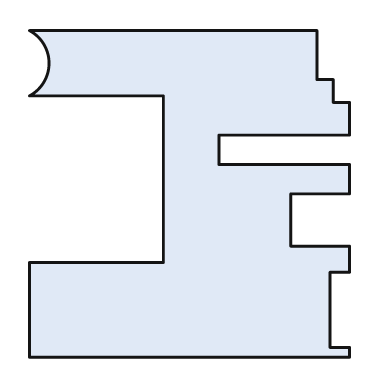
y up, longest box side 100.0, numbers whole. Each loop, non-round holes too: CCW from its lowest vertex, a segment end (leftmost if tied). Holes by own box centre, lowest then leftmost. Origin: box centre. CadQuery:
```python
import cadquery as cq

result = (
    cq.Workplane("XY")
    .moveTo(-49.0, -50.0)
    .lineTo(49.0, -50.0)
    .lineTo(49.0, -47.0)
    .lineTo(43.0, -47.0)
    .lineTo(43.0, -24.0)
    .lineTo(49.0, -24.0)
    .lineTo(49.0, -16.0)
    .lineTo(31.0, -16.0)
    .lineTo(31.0, 0.0)
    .lineTo(49.0, 0.0)
    .lineTo(49.0, 9.0)
    .lineTo(9.0, 9.0)
    .lineTo(9.0, 18.0)
    .lineTo(49.0, 18.0)
    .lineTo(49.0, 28.0)
    .lineTo(44.0, 28.0)
    .lineTo(44.0, 35.0)
    .lineTo(39.0, 35.0)
    .lineTo(39.0, 50.0)
    .lineTo(-49.0, 50.0)
    .threePointArc((-43.0, 40.0), (-49.0, 30.0))
    .lineTo(-8.0, 30.0)
    .lineTo(-8.0, -21.0)
    .lineTo(-49.0, -21.0)
    .close()
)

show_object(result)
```